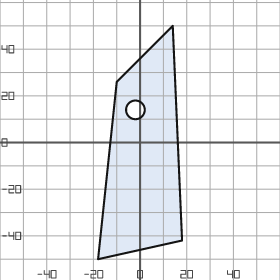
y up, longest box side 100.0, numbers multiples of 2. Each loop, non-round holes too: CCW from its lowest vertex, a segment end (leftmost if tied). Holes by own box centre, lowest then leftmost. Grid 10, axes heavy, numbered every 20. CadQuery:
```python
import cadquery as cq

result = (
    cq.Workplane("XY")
    .moveTo(-18.0, -50.0)
    .lineTo(18.0, -42.0)
    .lineTo(14.0, 50.0)
    .lineTo(-10.0, 26.0)
    .close()
    .moveTo(-2.0, 14.0)
    .circle(4.0)
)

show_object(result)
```